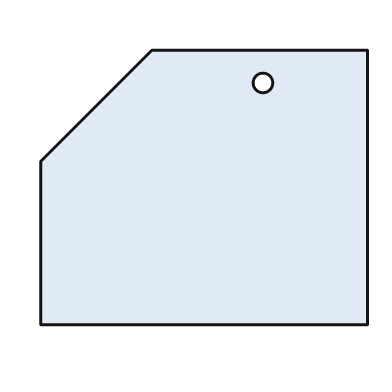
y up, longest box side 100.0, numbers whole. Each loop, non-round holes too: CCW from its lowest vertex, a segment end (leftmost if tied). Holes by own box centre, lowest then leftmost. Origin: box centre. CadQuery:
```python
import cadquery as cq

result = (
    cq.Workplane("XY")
    .moveTo(-50.0, -42.0)
    .lineTo(50.0, -42.0)
    .lineTo(50.0, 42.0)
    .lineTo(-16.0, 42.0)
    .lineTo(-50.0, 8.0)
    .close()
    .moveTo(18.0, 32.0)
    .circle(3.0)
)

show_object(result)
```